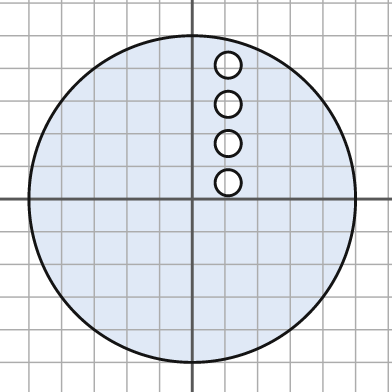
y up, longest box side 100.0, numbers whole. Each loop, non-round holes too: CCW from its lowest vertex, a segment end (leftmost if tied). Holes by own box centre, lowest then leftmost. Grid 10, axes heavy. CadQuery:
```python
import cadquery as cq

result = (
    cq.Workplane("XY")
    .moveTo(0.0, 0.0)
    .circle(50.0)
    .moveTo(11.0, 5.0)
    .circle(4.0)
    .moveTo(11.0, 17.0)
    .circle(4.0)
    .moveTo(11.0, 29.0)
    .circle(4.0)
    .moveTo(11.0, 41.0)
    .circle(4.0)
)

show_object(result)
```